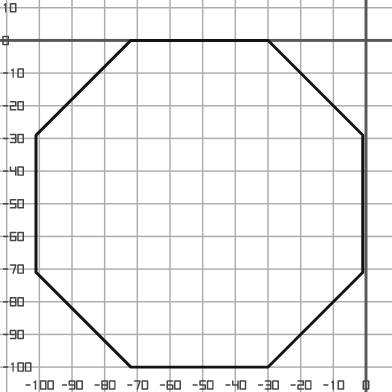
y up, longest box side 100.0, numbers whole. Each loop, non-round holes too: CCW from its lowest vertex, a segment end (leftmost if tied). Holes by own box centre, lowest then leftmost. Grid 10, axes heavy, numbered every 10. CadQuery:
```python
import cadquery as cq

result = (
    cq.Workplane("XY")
    .moveTo(-72.0, -100.0)
    .lineTo(-30.0, -100.0)
    .lineTo(-1.0, -71.0)
    .lineTo(-1.0, -29.0)
    .lineTo(-30.0, 0.0)
    .lineTo(-72.0, 0.0)
    .lineTo(-101.0, -29.0)
    .lineTo(-101.0, -71.0)
    .close()
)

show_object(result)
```